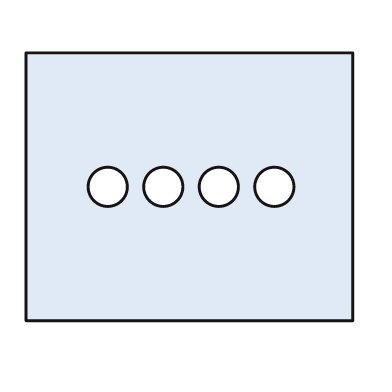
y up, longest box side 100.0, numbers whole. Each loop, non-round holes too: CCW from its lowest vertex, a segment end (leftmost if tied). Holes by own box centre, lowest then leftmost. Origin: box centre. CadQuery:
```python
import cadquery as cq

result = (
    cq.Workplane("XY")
    .moveTo(-50.0, -41.0)
    .lineTo(50.0, -41.0)
    .lineTo(50.0, 41.0)
    .lineTo(-50.0, 41.0)
    .close()
    .moveTo(-25.0, 0.0)
    .circle(6.0)
    .moveTo(-8.0, 0.0)
    .circle(6.0)
    .moveTo(9.0, 0.0)
    .circle(6.0)
    .moveTo(26.0, 0.0)
    .circle(6.0)
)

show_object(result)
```